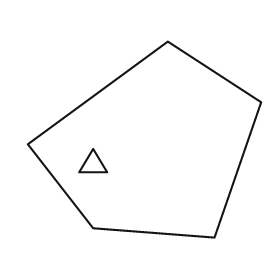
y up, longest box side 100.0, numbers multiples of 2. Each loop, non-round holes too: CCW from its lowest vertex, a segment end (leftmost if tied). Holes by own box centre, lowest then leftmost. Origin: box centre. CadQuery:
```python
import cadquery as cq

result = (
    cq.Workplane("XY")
    .moveTo(30.0, -42.0)
    .lineTo(50.0, 16.0)
    .lineTo(10.0, 42.0)
    .lineTo(-50.0, -2.0)
    .lineTo(-22.0, -38.0)
    .close()
    .moveTo(-28.0, -14.0)
    .lineTo(-16.0, -14.0)
    .lineTo(-22.0, -4.0)
    .close()
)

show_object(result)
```